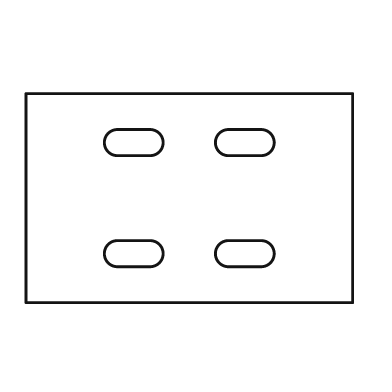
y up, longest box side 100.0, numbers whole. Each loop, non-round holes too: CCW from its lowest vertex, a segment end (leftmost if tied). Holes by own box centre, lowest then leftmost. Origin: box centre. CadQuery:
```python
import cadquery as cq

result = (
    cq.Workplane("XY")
    .moveTo(-50.0, -32.0)
    .lineTo(50.0, -32.0)
    .lineTo(50.0, 32.0)
    .lineTo(-50.0, 32.0)
    .close()
    .moveTo(-22.0, -21.0)
    .lineTo(-12.0, -21.0)
    .threePointArc((-8.0, -17.0), (-12.0, -13.0))
    .lineTo(-22.0, -13.0)
    .threePointArc((-26.0, -17.0), (-22.0, -21.0))
    .close()
    .moveTo(12.0, -21.0)
    .lineTo(22.0, -21.0)
    .threePointArc((26.0, -17.0), (22.0, -13.0))
    .lineTo(12.0, -13.0)
    .threePointArc((8.0, -17.0), (12.0, -21.0))
    .close()
    .moveTo(-22.0, 13.0)
    .lineTo(-12.0, 13.0)
    .threePointArc((-8.0, 17.0), (-12.0, 21.0))
    .lineTo(-22.0, 21.0)
    .threePointArc((-26.0, 17.0), (-22.0, 13.0))
    .close()
    .moveTo(12.0, 13.0)
    .lineTo(22.0, 13.0)
    .threePointArc((26.0, 17.0), (22.0, 21.0))
    .lineTo(12.0, 21.0)
    .threePointArc((8.0, 17.0), (12.0, 13.0))
    .close()
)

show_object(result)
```